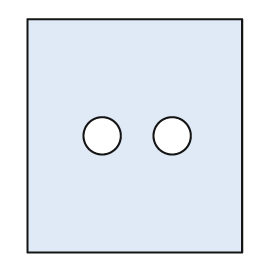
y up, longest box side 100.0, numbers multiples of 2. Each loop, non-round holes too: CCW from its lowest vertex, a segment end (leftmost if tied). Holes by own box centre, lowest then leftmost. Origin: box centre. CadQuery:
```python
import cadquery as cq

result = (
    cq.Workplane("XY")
    .moveTo(-46.0, -50.0)
    .lineTo(46.0, -50.0)
    .lineTo(46.0, 50.0)
    .lineTo(-46.0, 50.0)
    .close()
    .moveTo(-14.0, 0.0)
    .circle(8.0)
    .moveTo(16.0, 0.0)
    .circle(8.0)
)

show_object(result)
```